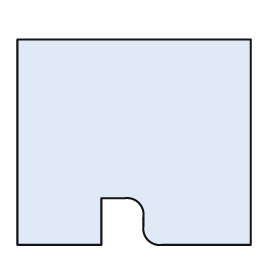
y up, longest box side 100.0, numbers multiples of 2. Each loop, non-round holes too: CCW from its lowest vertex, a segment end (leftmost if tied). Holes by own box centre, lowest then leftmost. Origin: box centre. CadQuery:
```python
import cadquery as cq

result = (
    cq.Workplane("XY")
    .moveTo(-50.0, -44.0)
    .lineTo(-14.0, -44.0)
    .lineTo(-14.0, -24.0)
    .lineTo(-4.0, -24.0)
    .threePointArc((2.0, -26.0), (4.0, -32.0))
    .lineTo(4.0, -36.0)
    .threePointArc((6.0, -42.0), (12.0, -44.0))
    .lineTo(50.0, -44.0)
    .lineTo(50.0, 44.0)
    .lineTo(-50.0, 44.0)
    .close()
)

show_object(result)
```